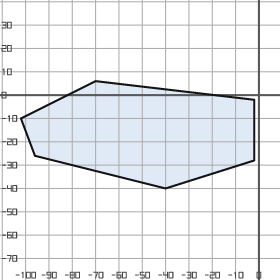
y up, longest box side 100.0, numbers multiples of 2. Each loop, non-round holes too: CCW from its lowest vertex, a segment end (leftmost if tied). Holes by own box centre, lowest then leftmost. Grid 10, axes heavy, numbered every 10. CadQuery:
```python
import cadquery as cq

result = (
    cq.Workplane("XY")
    .moveTo(-40.0, -40.0)
    .lineTo(-2.0, -28.0)
    .lineTo(-2.0, -2.0)
    .lineTo(-70.0, 6.0)
    .lineTo(-102.0, -10.0)
    .lineTo(-96.0, -26.0)
    .close()
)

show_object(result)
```